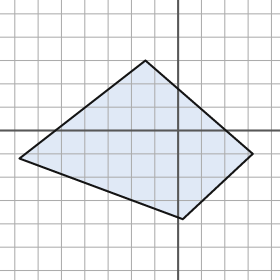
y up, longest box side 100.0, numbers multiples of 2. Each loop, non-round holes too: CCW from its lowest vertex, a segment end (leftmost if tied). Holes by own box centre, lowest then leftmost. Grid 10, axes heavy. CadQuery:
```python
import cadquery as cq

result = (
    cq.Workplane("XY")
    .moveTo(2.0, -38.0)
    .lineTo(32.0, -10.0)
    .lineTo(-14.0, 30.0)
    .lineTo(-68.0, -12.0)
    .close()
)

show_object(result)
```